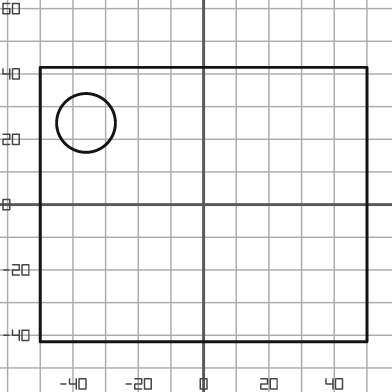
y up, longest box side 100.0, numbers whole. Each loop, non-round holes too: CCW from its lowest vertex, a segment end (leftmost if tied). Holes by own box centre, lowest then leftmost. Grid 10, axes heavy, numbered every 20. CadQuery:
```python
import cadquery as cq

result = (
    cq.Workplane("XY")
    .moveTo(-50.0, -42.0)
    .lineTo(50.0, -42.0)
    .lineTo(50.0, 42.0)
    .lineTo(-50.0, 42.0)
    .close()
    .moveTo(-36.0, 25.0)
    .circle(9.0)
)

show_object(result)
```